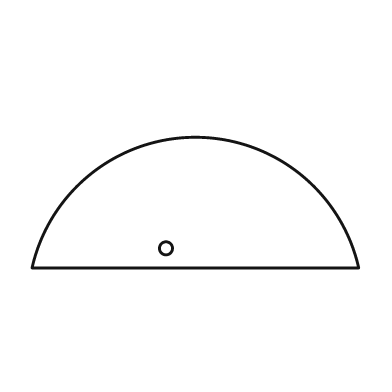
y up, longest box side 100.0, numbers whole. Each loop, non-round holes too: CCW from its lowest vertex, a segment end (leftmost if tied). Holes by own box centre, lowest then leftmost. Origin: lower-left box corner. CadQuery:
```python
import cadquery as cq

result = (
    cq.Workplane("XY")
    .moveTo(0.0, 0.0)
    .lineTo(100.0, 0.0)
    .threePointArc((50.0, 40.0), (0.0, 0.0))
    .close()
    .moveTo(41.0, 6.0)
    .circle(2.0)
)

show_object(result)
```